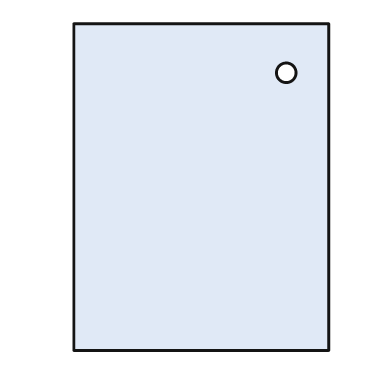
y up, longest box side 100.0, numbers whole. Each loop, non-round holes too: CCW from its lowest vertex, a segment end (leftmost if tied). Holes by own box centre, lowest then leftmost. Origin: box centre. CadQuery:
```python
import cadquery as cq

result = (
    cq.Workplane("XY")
    .moveTo(-39.0, -50.0)
    .lineTo(39.0, -50.0)
    .lineTo(39.0, 50.0)
    .lineTo(-39.0, 50.0)
    .close()
    .moveTo(26.0, 35.0)
    .circle(3.0)
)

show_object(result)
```